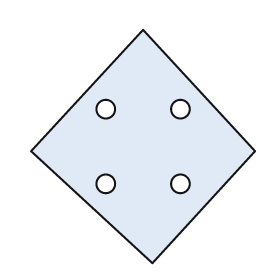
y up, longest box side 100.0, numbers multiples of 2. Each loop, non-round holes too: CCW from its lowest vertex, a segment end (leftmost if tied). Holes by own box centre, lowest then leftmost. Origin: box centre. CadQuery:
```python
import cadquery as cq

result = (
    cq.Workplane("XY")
    .moveTo(4.0, -50.0)
    .lineTo(48.0, -2.0)
    .lineTo(0.0, 50.0)
    .lineTo(-48.0, -2.0)
    .close()
    .moveTo(-16.0, -16.0)
    .circle(4.0)
    .moveTo(16.0, -16.0)
    .circle(4.0)
    .moveTo(-16.0, 16.0)
    .circle(4.0)
    .moveTo(16.0, 16.0)
    .circle(4.0)
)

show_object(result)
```